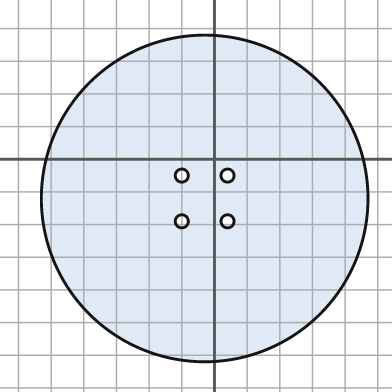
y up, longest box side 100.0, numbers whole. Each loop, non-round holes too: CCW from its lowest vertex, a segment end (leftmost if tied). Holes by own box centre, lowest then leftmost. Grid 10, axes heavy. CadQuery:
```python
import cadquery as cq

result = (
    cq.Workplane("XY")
    .moveTo(-3.0, -12.0)
    .circle(50.0)
    .moveTo(-10.0, -19.0)
    .circle(2.0)
    .moveTo(4.0, -19.0)
    .circle(2.0)
    .moveTo(-10.0, -5.0)
    .circle(2.0)
    .moveTo(4.0, -5.0)
    .circle(2.0)
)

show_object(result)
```